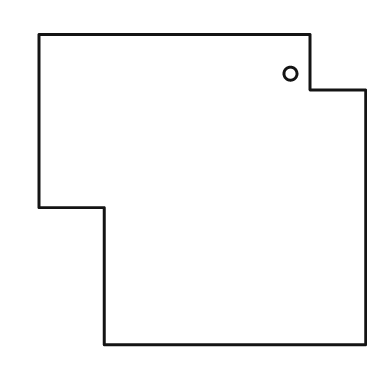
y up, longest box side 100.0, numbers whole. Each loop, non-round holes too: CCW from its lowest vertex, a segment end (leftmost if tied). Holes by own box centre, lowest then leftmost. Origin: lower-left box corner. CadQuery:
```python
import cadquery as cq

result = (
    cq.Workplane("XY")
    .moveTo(20.0, 0.0)
    .lineTo(100.0, 0.0)
    .lineTo(100.0, 78.0)
    .lineTo(83.0, 78.0)
    .lineTo(83.0, 95.0)
    .lineTo(0.0, 95.0)
    .lineTo(0.0, 42.0)
    .lineTo(20.0, 42.0)
    .close()
    .moveTo(77.0, 83.0)
    .circle(2.0)
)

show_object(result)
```